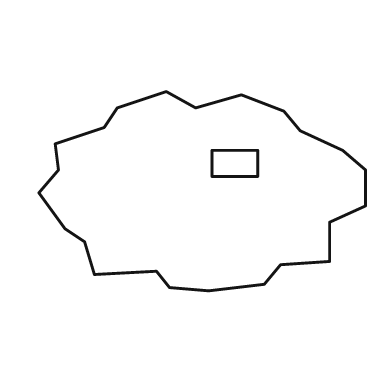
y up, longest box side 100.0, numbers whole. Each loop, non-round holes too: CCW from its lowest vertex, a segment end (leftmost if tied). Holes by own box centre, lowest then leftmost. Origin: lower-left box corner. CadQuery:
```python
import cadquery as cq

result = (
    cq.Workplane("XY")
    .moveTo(52.0, 0.0)
    .lineTo(69.0, 2.0)
    .lineTo(74.0, 8.0)
    .lineTo(89.0, 9.0)
    .lineTo(89.0, 21.0)
    .lineTo(100.0, 26.0)
    .lineTo(100.0, 37.0)
    .lineTo(93.0, 43.0)
    .lineTo(80.0, 49.0)
    .lineTo(75.0, 55.0)
    .lineTo(62.0, 60.0)
    .lineTo(48.0, 56.0)
    .lineTo(39.0, 61.0)
    .lineTo(24.0, 56.0)
    .lineTo(20.0, 50.0)
    .lineTo(5.0, 45.0)
    .lineTo(6.0, 37.0)
    .lineTo(0.0, 30.0)
    .lineTo(8.0, 19.0)
    .lineTo(14.0, 15.0)
    .lineTo(17.0, 5.0)
    .lineTo(36.0, 6.0)
    .lineTo(40.0, 1.0)
    .close()
    .moveTo(53.0, 35.0)
    .lineTo(67.0, 35.0)
    .lineTo(67.0, 43.0)
    .lineTo(53.0, 43.0)
    .close()
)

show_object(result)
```